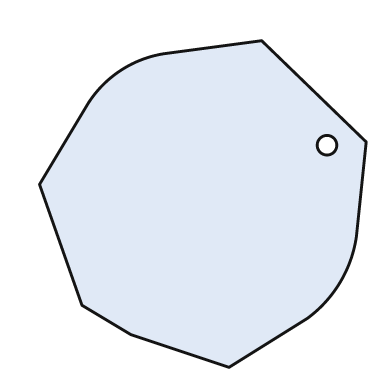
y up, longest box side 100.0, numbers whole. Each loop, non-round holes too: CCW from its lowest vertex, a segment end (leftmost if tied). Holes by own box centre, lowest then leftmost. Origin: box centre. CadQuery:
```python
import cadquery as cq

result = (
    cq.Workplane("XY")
    .moveTo(8.0, -50.0)
    .lineTo(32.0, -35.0)
    .threePointArc((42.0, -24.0), (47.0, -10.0))
    .lineTo(50.0, 19.0)
    .lineTo(18.0, 50.0)
    .lineTo(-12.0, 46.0)
    .threePointArc((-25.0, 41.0), (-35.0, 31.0))
    .lineTo(-50.0, 6.0)
    .lineTo(-37.0, -31.0)
    .lineTo(-22.0, -40.0)
    .close()
    .moveTo(38.0, 18.0)
    .circle(3.0)
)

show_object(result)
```